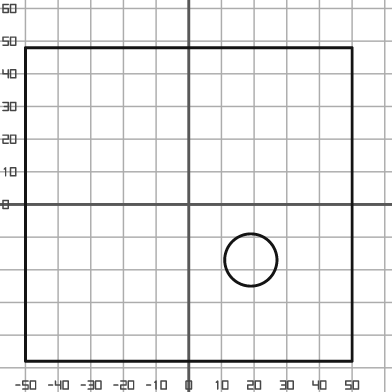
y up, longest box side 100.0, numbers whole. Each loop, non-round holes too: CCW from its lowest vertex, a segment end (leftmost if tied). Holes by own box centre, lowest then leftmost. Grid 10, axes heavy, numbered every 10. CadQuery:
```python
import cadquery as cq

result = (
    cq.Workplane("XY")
    .moveTo(-50.0, -48.0)
    .lineTo(50.0, -48.0)
    .lineTo(50.0, 48.0)
    .lineTo(-50.0, 48.0)
    .close()
    .moveTo(19.0, -17.0)
    .circle(8.0)
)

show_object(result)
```